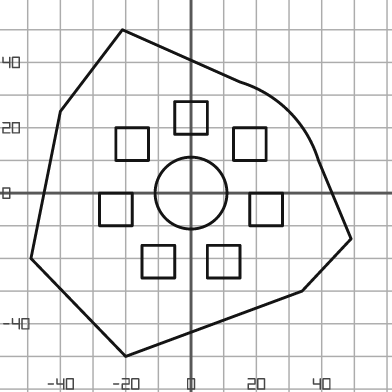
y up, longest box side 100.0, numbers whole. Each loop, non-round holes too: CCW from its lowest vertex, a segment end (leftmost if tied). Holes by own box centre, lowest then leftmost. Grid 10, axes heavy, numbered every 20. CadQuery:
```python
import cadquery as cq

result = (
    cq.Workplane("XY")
    .moveTo(-20.0, -50.0)
    .lineTo(34.0, -30.0)
    .lineTo(49.0, -14.0)
    .lineTo(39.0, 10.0)
    .threePointArc((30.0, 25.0), (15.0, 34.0))
    .lineTo(-21.0, 50.0)
    .lineTo(-40.0, 25.0)
    .lineTo(-49.0, -20.0)
    .close()
    .moveTo(-15.0, -26.0)
    .lineTo(-5.0, -26.0)
    .lineTo(-5.0, -16.0)
    .lineTo(-15.0, -16.0)
    .close()
    .moveTo(5.0, -26.0)
    .lineTo(15.0, -26.0)
    .lineTo(15.0, -16.0)
    .lineTo(5.0, -16.0)
    .close()
    .moveTo(-28.0, -10.0)
    .lineTo(-18.0, -10.0)
    .lineTo(-18.0, 0.0)
    .lineTo(-28.0, 0.0)
    .close()
    .moveTo(18.0, -10.0)
    .lineTo(28.0, -10.0)
    .lineTo(28.0, 0.0)
    .lineTo(18.0, 0.0)
    .close()
    .moveTo(0.0, 0.0)
    .circle(11.0)
    .moveTo(-23.0, 10.0)
    .lineTo(-13.0, 10.0)
    .lineTo(-13.0, 20.0)
    .lineTo(-23.0, 20.0)
    .close()
    .moveTo(13.0, 10.0)
    .lineTo(23.0, 10.0)
    .lineTo(23.0, 20.0)
    .lineTo(13.0, 20.0)
    .close()
    .moveTo(-5.0, 18.0)
    .lineTo(5.0, 18.0)
    .lineTo(5.0, 28.0)
    .lineTo(-5.0, 28.0)
    .close()
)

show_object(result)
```